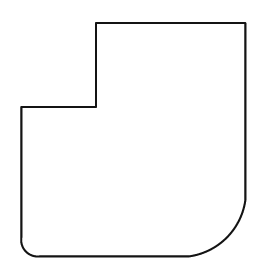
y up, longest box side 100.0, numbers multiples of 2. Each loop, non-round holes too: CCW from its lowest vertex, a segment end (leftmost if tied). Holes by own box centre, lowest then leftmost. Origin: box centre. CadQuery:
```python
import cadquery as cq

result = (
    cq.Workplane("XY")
    .moveTo(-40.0, -50.0)
    .lineTo(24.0, -50.0)
    .threePointArc((40.0, -42.0), (48.0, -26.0))
    .lineTo(48.0, 50.0)
    .lineTo(-16.0, 50.0)
    .lineTo(-16.0, 14.0)
    .lineTo(-48.0, 14.0)
    .lineTo(-48.0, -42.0)
    .threePointArc((-46.0, -48.0), (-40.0, -50.0))
    .close()
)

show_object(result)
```